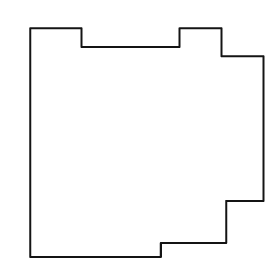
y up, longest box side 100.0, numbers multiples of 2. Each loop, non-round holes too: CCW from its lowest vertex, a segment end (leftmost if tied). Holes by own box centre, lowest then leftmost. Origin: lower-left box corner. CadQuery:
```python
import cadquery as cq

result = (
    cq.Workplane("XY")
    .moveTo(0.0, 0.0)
    .lineTo(56.0, 0.0)
    .lineTo(56.0, 6.0)
    .lineTo(84.0, 6.0)
    .lineTo(84.0, 24.0)
    .lineTo(100.0, 24.0)
    .lineTo(100.0, 86.0)
    .lineTo(82.0, 86.0)
    .lineTo(82.0, 98.0)
    .lineTo(64.0, 98.0)
    .lineTo(64.0, 90.0)
    .lineTo(22.0, 90.0)
    .lineTo(22.0, 98.0)
    .lineTo(0.0, 98.0)
    .close()
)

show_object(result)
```